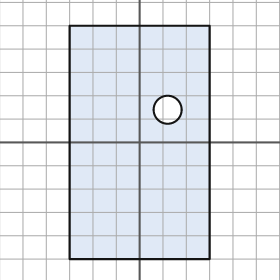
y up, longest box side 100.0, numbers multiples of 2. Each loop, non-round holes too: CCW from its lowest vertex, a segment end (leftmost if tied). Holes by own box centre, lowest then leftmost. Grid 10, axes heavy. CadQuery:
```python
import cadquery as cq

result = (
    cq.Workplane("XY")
    .moveTo(-30.0, -50.0)
    .lineTo(30.0, -50.0)
    .lineTo(30.0, 50.0)
    .lineTo(-30.0, 50.0)
    .close()
    .moveTo(12.0, 14.0)
    .circle(6.0)
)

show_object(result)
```